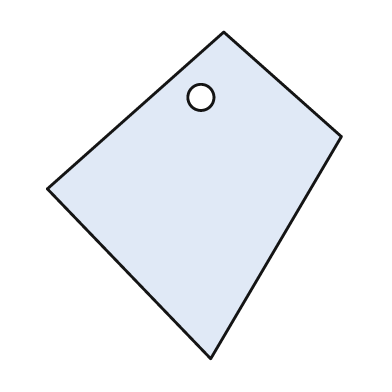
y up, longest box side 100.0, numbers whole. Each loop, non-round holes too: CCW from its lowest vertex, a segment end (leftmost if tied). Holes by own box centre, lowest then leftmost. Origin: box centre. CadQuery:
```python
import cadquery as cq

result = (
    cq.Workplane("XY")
    .moveTo(5.0, -50.0)
    .lineTo(45.0, 18.0)
    .lineTo(9.0, 50.0)
    .lineTo(-45.0, 2.0)
    .close()
    .moveTo(2.0, 30.0)
    .circle(4.0)
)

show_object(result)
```